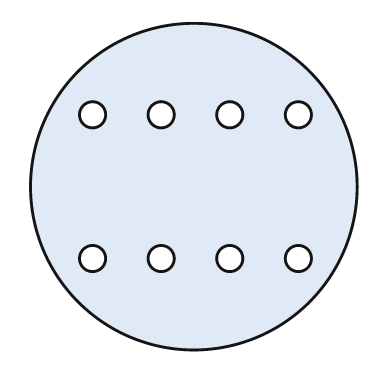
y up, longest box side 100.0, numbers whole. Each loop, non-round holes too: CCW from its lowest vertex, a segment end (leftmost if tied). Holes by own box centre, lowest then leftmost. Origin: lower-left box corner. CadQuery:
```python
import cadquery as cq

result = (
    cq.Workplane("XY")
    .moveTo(50.0, 50.0)
    .circle(50.0)
    .moveTo(19.0, 28.0)
    .circle(4.0)
    .moveTo(40.0, 28.0)
    .circle(4.0)
    .moveTo(61.0, 28.0)
    .circle(4.0)
    .moveTo(82.0, 28.0)
    .circle(4.0)
    .moveTo(19.0, 72.0)
    .circle(4.0)
    .moveTo(40.0, 72.0)
    .circle(4.0)
    .moveTo(61.0, 72.0)
    .circle(4.0)
    .moveTo(82.0, 72.0)
    .circle(4.0)
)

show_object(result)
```